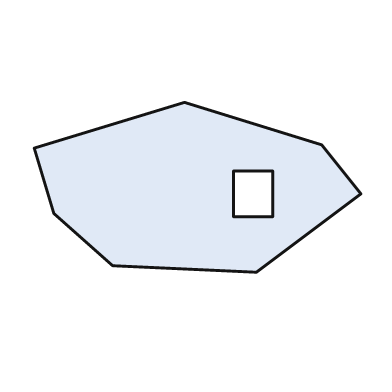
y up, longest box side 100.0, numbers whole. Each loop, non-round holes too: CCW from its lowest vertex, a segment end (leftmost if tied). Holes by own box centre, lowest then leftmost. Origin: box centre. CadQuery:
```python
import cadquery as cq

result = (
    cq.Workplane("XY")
    .moveTo(18.0, -26.0)
    .lineTo(50.0, -2.0)
    .lineTo(38.0, 13.0)
    .lineTo(-4.0, 26.0)
    .lineTo(-50.0, 12.0)
    .lineTo(-44.0, -8.0)
    .lineTo(-26.0, -24.0)
    .close()
    .moveTo(11.0, -9.0)
    .lineTo(23.0, -9.0)
    .lineTo(23.0, 5.0)
    .lineTo(11.0, 5.0)
    .close()
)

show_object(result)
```